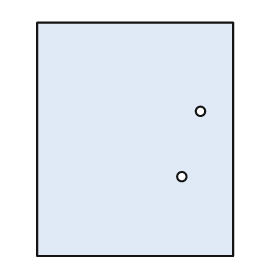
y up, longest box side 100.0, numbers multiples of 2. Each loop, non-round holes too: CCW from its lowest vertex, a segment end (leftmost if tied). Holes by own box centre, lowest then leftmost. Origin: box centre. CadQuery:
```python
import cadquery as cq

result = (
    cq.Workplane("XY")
    .moveTo(-42.0, -50.0)
    .lineTo(42.0, -50.0)
    .lineTo(42.0, 50.0)
    .lineTo(-42.0, 50.0)
    .close()
    .moveTo(20.0, -16.0)
    .circle(2.0)
    .moveTo(28.0, 12.0)
    .circle(2.0)
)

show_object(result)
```